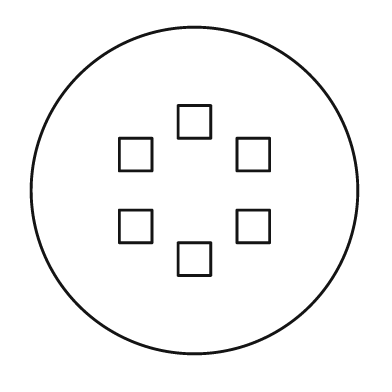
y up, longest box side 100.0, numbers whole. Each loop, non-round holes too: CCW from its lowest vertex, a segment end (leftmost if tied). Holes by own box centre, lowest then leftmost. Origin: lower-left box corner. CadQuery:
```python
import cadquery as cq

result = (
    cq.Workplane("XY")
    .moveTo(50.0, 50.0)
    .circle(50.0)
    .moveTo(45.0, 24.0)
    .lineTo(55.0, 24.0)
    .lineTo(55.0, 34.0)
    .lineTo(45.0, 34.0)
    .close()
    .moveTo(27.0, 34.0)
    .lineTo(37.0, 34.0)
    .lineTo(37.0, 44.0)
    .lineTo(27.0, 44.0)
    .close()
    .moveTo(63.0, 34.0)
    .lineTo(73.0, 34.0)
    .lineTo(73.0, 44.0)
    .lineTo(63.0, 44.0)
    .close()
    .moveTo(27.0, 56.0)
    .lineTo(37.0, 56.0)
    .lineTo(37.0, 66.0)
    .lineTo(27.0, 66.0)
    .close()
    .moveTo(63.0, 56.0)
    .lineTo(73.0, 56.0)
    .lineTo(73.0, 66.0)
    .lineTo(63.0, 66.0)
    .close()
    .moveTo(45.0, 66.0)
    .lineTo(55.0, 66.0)
    .lineTo(55.0, 76.0)
    .lineTo(45.0, 76.0)
    .close()
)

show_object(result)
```